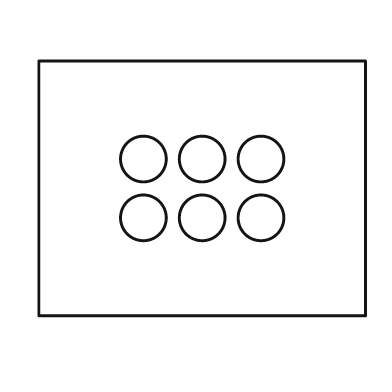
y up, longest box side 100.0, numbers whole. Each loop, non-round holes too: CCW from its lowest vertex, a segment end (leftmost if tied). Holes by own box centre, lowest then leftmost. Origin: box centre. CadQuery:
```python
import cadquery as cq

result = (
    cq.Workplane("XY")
    .moveTo(-50.0, -39.0)
    .lineTo(50.0, -39.0)
    .lineTo(50.0, 39.0)
    .lineTo(-50.0, 39.0)
    .close()
    .moveTo(-18.0, -9.0)
    .circle(7.0)
    .moveTo(0.0, -9.0)
    .circle(7.0)
    .moveTo(18.0, -9.0)
    .circle(7.0)
    .moveTo(-18.0, 9.0)
    .circle(7.0)
    .moveTo(0.0, 9.0)
    .circle(7.0)
    .moveTo(18.0, 9.0)
    .circle(7.0)
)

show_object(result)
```